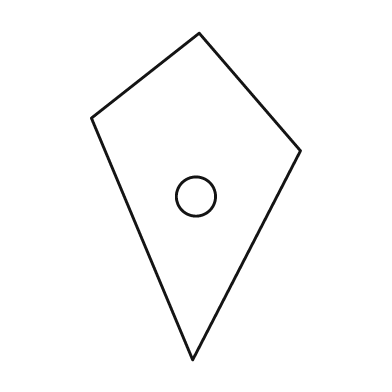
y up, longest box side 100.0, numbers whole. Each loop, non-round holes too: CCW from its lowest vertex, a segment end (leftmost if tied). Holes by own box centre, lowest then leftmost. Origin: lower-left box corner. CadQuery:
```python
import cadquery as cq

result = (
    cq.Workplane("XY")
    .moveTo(31.0, 0.0)
    .lineTo(64.0, 64.0)
    .lineTo(33.0, 100.0)
    .lineTo(0.0, 74.0)
    .close()
    .moveTo(32.0, 50.0)
    .circle(6.0)
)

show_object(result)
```